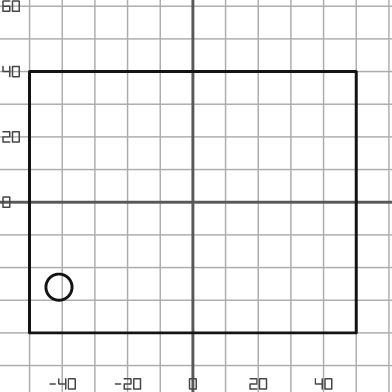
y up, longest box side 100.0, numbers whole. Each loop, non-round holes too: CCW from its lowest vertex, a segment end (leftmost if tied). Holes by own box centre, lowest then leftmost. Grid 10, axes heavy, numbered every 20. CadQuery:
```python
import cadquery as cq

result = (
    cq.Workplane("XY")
    .moveTo(-50.0, -40.0)
    .lineTo(50.0, -40.0)
    .lineTo(50.0, 40.0)
    .lineTo(-50.0, 40.0)
    .close()
    .moveTo(-41.0, -26.0)
    .circle(4.0)
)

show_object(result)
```